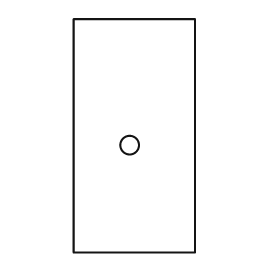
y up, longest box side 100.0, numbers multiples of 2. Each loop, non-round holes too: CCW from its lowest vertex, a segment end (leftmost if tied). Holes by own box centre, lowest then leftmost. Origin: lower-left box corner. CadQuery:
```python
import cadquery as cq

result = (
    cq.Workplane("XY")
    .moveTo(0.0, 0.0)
    .lineTo(52.0, 0.0)
    .lineTo(52.0, 100.0)
    .lineTo(0.0, 100.0)
    .close()
    .moveTo(24.0, 46.0)
    .circle(4.0)
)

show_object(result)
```